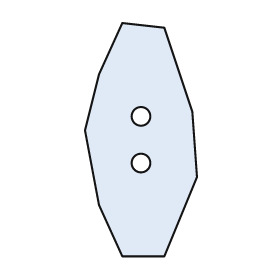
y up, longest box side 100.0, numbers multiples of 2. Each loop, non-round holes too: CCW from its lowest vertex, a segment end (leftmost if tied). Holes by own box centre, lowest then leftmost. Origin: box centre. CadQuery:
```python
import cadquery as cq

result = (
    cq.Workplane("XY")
    .moveTo(-8.0, -50.0)
    .lineTo(10.0, -50.0)
    .lineTo(24.0, -16.0)
    .lineTo(22.0, 12.0)
    .lineTo(10.0, 48.0)
    .lineTo(-8.0, 50.0)
    .lineTo(-18.0, 28.0)
    .lineTo(-24.0, 4.0)
    .lineTo(-18.0, -28.0)
    .close()
    .moveTo(0.0, -10.0)
    .circle(4.0)
    .moveTo(0.0, 10.0)
    .circle(4.0)
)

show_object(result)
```